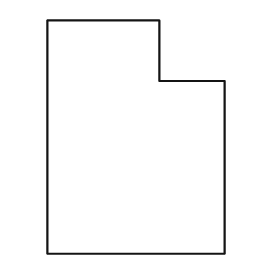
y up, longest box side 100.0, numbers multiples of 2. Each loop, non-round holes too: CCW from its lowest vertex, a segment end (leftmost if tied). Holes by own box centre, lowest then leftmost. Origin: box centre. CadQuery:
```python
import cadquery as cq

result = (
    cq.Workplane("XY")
    .moveTo(-38.0, -50.0)
    .lineTo(38.0, -50.0)
    .lineTo(38.0, 24.0)
    .lineTo(10.0, 24.0)
    .lineTo(10.0, 50.0)
    .lineTo(-38.0, 50.0)
    .close()
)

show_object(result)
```